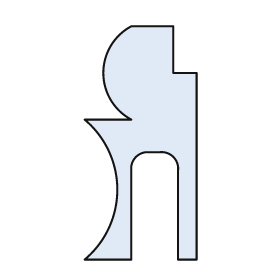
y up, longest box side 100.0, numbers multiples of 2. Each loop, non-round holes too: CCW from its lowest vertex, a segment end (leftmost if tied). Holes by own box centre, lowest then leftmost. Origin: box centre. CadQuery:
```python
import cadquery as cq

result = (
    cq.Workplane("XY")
    .moveTo(-24.0, -50.0)
    .lineTo(-4.0, -50.0)
    .lineTo(-4.0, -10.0)
    .threePointArc((-2.0, -6.0), (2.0, -4.0))
    .lineTo(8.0, -4.0)
    .threePointArc((14.0, -6.0), (16.0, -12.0))
    .lineTo(16.0, -50.0)
    .lineTo(24.0, -50.0)
    .lineTo(24.0, 30.0)
    .lineTo(14.0, 30.0)
    .lineTo(14.0, 50.0)
    .lineTo(-4.0, 50.0)
    .threePointArc((-16.0, 30.0), (-4.0, 10.0))
    .lineTo(-24.0, 10.0)
    .threePointArc((-10.0, -20.0), (-24.0, -50.0))
    .close()
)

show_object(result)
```